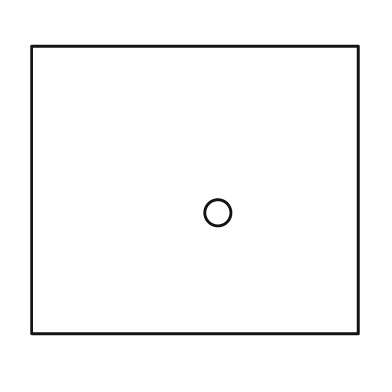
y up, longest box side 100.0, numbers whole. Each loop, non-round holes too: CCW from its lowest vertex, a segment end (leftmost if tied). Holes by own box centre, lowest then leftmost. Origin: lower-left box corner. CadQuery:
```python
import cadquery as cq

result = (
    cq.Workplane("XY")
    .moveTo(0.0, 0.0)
    .lineTo(100.0, 0.0)
    .lineTo(100.0, 88.0)
    .lineTo(0.0, 88.0)
    .close()
    .moveTo(57.0, 37.0)
    .circle(4.0)
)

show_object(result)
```